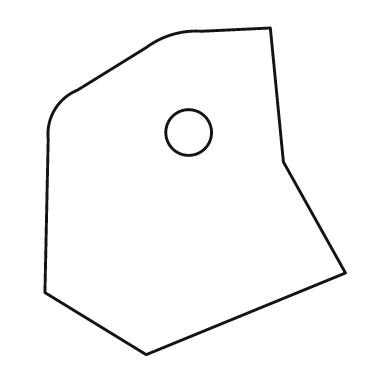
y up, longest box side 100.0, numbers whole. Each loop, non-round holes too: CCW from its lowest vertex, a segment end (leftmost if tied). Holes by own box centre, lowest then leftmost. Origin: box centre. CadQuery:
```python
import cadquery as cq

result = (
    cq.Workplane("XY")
    .moveTo(-15.0, -50.0)
    .lineTo(46.0, -25.0)
    .lineTo(27.0, 9.0)
    .lineTo(23.0, 50.0)
    .lineTo(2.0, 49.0)
    .threePointArc((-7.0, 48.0), (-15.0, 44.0))
    .lineTo(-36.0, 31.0)
    .threePointArc((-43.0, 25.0), (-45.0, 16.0))
    .lineTo(-46.0, -31.0)
    .close()
    .moveTo(-2.0, 18.0)
    .circle(7.0)
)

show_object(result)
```